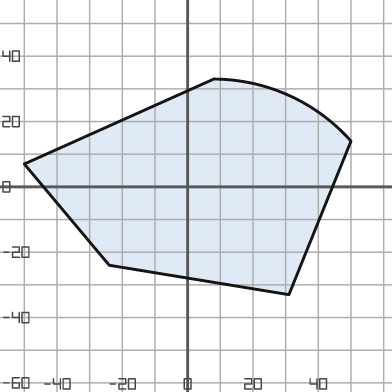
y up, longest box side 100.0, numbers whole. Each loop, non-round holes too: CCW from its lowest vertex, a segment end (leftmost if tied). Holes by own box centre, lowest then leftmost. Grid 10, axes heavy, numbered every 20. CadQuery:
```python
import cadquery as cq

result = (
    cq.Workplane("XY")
    .moveTo(31.0, -33.0)
    .lineTo(50.0, 14.0)
    .threePointArc((31.0, 28.0), (8.0, 33.0))
    .lineTo(-50.0, 7.0)
    .lineTo(-24.0, -24.0)
    .close()
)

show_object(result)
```